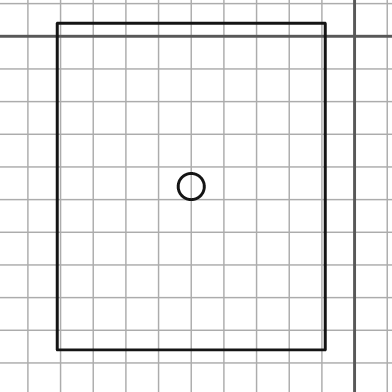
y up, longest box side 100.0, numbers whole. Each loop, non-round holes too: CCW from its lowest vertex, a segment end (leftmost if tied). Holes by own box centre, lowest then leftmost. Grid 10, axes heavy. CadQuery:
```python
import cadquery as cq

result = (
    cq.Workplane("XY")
    .moveTo(-91.0, -96.0)
    .lineTo(-9.0, -96.0)
    .lineTo(-9.0, 4.0)
    .lineTo(-91.0, 4.0)
    .close()
    .moveTo(-50.0, -46.0)
    .circle(4.0)
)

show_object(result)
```